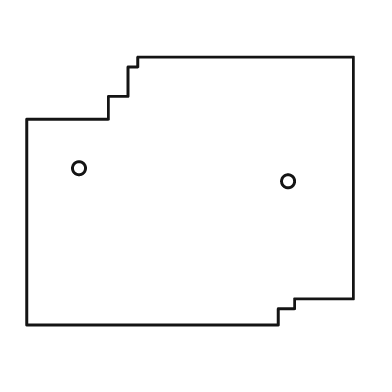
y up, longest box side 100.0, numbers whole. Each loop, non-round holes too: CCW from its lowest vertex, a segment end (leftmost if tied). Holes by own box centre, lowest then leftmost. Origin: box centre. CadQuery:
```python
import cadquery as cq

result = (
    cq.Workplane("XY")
    .moveTo(-50.0, -41.0)
    .lineTo(27.0, -41.0)
    .lineTo(27.0, -36.0)
    .lineTo(32.0, -36.0)
    .lineTo(32.0, -33.0)
    .lineTo(50.0, -33.0)
    .lineTo(50.0, 41.0)
    .lineTo(-16.0, 41.0)
    .lineTo(-16.0, 38.0)
    .lineTo(-19.0, 38.0)
    .lineTo(-19.0, 29.0)
    .lineTo(-25.0, 29.0)
    .lineTo(-25.0, 22.0)
    .lineTo(-50.0, 22.0)
    .close()
    .moveTo(30.0, 3.0)
    .circle(2.0)
    .moveTo(-34.0, 7.0)
    .circle(2.0)
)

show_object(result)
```